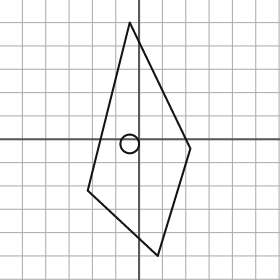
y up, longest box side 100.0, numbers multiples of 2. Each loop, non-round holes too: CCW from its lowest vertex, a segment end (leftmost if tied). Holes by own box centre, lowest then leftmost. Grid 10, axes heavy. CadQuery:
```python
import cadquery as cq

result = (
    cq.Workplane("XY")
    .moveTo(8.0, -50.0)
    .lineTo(22.0, -4.0)
    .lineTo(-4.0, 50.0)
    .lineTo(-22.0, -22.0)
    .close()
    .moveTo(-4.0, -2.0)
    .circle(4.0)
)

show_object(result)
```